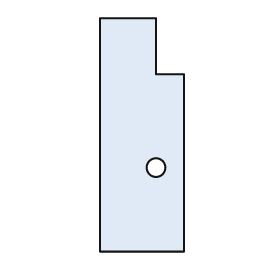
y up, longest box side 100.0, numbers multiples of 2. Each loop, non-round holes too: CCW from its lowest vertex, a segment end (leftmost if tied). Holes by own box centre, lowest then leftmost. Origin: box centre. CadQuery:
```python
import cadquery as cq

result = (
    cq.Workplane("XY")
    .moveTo(-18.0, -50.0)
    .lineTo(18.0, -50.0)
    .lineTo(18.0, 26.0)
    .lineTo(6.0, 26.0)
    .lineTo(6.0, 50.0)
    .lineTo(-18.0, 50.0)
    .close()
    .moveTo(6.0, -14.0)
    .circle(4.0)
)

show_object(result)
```